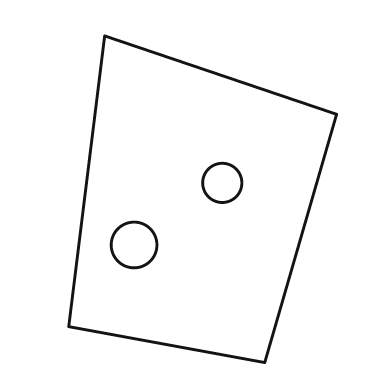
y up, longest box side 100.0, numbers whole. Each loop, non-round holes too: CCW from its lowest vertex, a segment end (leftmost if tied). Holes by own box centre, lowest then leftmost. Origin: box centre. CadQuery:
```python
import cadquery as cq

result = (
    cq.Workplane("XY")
    .moveTo(19.0, -50.0)
    .lineTo(41.0, 26.0)
    .lineTo(-30.0, 50.0)
    .lineTo(-41.0, -39.0)
    .close()
    .moveTo(-21.0, -14.0)
    .circle(7.0)
    .moveTo(6.0, 5.0)
    .circle(6.0)
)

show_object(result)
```